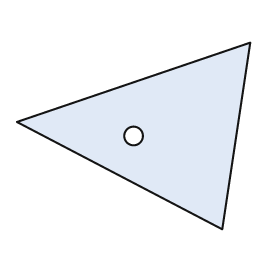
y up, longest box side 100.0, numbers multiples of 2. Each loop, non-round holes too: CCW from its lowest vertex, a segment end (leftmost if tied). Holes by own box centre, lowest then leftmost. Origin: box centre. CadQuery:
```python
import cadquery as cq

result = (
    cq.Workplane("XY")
    .moveTo(38.0, -40.0)
    .lineTo(50.0, 40.0)
    .lineTo(-50.0, 6.0)
    .close()
    .moveTo(0.0, 0.0)
    .circle(4.0)
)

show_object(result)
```